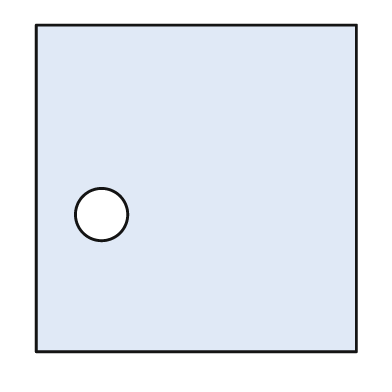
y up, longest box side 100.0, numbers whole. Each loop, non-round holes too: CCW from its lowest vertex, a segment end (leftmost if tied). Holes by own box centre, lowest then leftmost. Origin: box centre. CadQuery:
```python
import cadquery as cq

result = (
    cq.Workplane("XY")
    .moveTo(-49.0, -50.0)
    .lineTo(49.0, -50.0)
    .lineTo(49.0, 50.0)
    .lineTo(-49.0, 50.0)
    .close()
    .moveTo(-29.0, -8.0)
    .circle(8.0)
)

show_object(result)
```